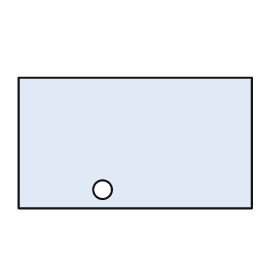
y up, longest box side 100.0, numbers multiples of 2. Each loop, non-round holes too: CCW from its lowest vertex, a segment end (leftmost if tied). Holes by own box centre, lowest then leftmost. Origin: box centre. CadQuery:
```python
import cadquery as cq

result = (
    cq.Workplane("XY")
    .moveTo(-50.0, -28.0)
    .lineTo(50.0, -28.0)
    .lineTo(50.0, 28.0)
    .lineTo(-50.0, 28.0)
    .close()
    .moveTo(-14.0, -20.0)
    .circle(4.0)
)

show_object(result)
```